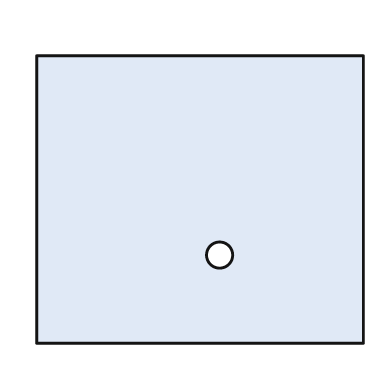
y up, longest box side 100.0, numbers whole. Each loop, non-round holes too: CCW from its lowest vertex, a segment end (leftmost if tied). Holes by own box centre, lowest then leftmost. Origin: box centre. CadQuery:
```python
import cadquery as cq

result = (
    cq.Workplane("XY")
    .moveTo(-50.0, -44.0)
    .lineTo(50.0, -44.0)
    .lineTo(50.0, 44.0)
    .lineTo(-50.0, 44.0)
    .close()
    .moveTo(6.0, -17.0)
    .circle(4.0)
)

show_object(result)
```